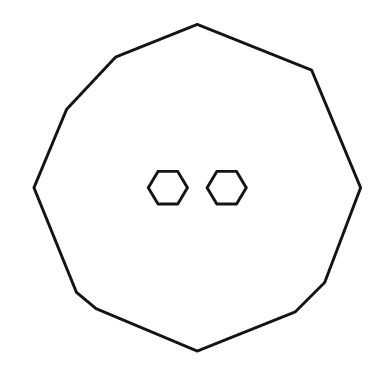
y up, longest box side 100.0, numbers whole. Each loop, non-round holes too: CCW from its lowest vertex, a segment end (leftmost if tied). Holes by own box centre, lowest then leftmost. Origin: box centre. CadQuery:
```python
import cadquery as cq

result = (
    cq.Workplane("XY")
    .moveTo(0.0, -50.0)
    .lineTo(30.0, -38.0)
    .lineTo(39.0, -29.0)
    .lineTo(50.0, 0.0)
    .lineTo(35.0, 36.0)
    .lineTo(0.0, 50.0)
    .lineTo(-25.0, 40.0)
    .lineTo(-40.0, 24.0)
    .lineTo(-50.0, 0.0)
    .lineTo(-37.0, -32.0)
    .lineTo(-31.0, -37.0)
    .close()
    .moveTo(-12.0, -5.0)
    .lineTo(-6.0, -5.0)
    .lineTo(-3.0, 0.0)
    .lineTo(-6.0, 5.0)
    .lineTo(-12.0, 5.0)
    .lineTo(-15.0, 0.0)
    .close()
    .moveTo(6.0, -5.0)
    .lineTo(12.0, -5.0)
    .lineTo(15.0, 0.0)
    .lineTo(12.0, 5.0)
    .lineTo(6.0, 5.0)
    .lineTo(3.0, 0.0)
    .close()
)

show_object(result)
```